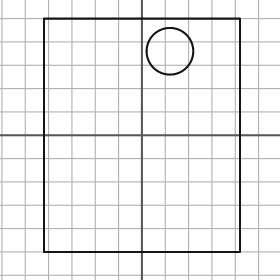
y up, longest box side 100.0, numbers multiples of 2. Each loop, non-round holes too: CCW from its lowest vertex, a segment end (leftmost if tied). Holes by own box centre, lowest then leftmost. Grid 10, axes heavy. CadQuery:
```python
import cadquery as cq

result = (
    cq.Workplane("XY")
    .moveTo(-42.0, -50.0)
    .lineTo(42.0, -50.0)
    .lineTo(42.0, 50.0)
    .lineTo(-42.0, 50.0)
    .close()
    .moveTo(12.0, 36.0)
    .circle(10.0)
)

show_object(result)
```